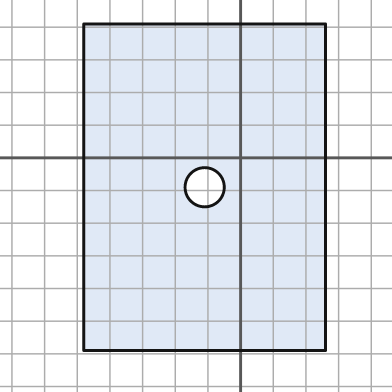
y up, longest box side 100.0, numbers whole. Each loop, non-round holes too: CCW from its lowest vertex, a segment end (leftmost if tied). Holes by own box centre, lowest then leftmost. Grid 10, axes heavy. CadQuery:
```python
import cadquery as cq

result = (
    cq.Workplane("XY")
    .moveTo(-48.0, -59.0)
    .lineTo(26.0, -59.0)
    .lineTo(26.0, 41.0)
    .lineTo(-48.0, 41.0)
    .close()
    .moveTo(-11.0, -9.0)
    .circle(6.0)
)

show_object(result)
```